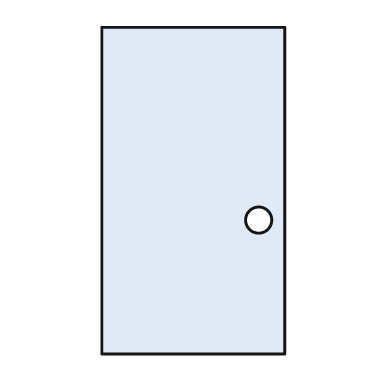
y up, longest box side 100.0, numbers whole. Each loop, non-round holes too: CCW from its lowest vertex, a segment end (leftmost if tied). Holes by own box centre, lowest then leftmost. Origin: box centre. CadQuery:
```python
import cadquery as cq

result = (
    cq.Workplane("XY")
    .moveTo(-28.0, -50.0)
    .lineTo(28.0, -50.0)
    .lineTo(28.0, 50.0)
    .lineTo(-28.0, 50.0)
    .close()
    .moveTo(20.0, -9.0)
    .circle(4.0)
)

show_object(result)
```